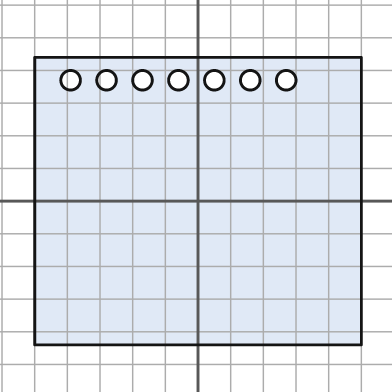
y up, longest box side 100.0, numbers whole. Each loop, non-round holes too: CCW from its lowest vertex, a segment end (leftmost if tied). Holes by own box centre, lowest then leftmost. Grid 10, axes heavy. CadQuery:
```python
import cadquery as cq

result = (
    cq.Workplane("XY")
    .moveTo(-50.0, -44.0)
    .lineTo(50.0, -44.0)
    .lineTo(50.0, 44.0)
    .lineTo(-50.0, 44.0)
    .close()
    .moveTo(-39.0, 37.0)
    .circle(3.0)
    .moveTo(-28.0, 37.0)
    .circle(3.0)
    .moveTo(-17.0, 37.0)
    .circle(3.0)
    .moveTo(-6.0, 37.0)
    .circle(3.0)
    .moveTo(5.0, 37.0)
    .circle(3.0)
    .moveTo(16.0, 37.0)
    .circle(3.0)
    .moveTo(27.0, 37.0)
    .circle(3.0)
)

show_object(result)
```